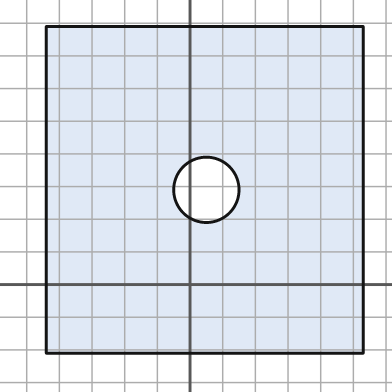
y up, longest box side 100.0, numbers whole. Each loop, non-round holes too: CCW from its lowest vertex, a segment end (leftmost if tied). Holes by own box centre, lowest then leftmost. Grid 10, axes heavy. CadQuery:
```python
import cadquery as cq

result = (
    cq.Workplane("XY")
    .moveTo(-44.0, -21.0)
    .lineTo(53.0, -21.0)
    .lineTo(53.0, 79.0)
    .lineTo(-44.0, 79.0)
    .close()
    .moveTo(5.0, 29.0)
    .circle(10.0)
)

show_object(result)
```